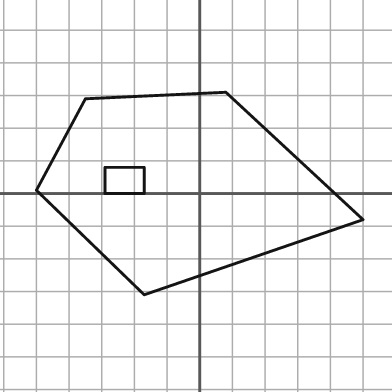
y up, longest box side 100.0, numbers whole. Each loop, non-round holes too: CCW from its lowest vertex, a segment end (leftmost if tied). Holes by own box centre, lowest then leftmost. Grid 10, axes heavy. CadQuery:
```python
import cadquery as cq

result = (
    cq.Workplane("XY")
    .moveTo(-17.0, -31.0)
    .lineTo(50.0, -8.0)
    .lineTo(8.0, 31.0)
    .lineTo(-35.0, 29.0)
    .lineTo(-50.0, 1.0)
    .close()
    .moveTo(-29.0, 0.0)
    .lineTo(-17.0, 0.0)
    .lineTo(-17.0, 8.0)
    .lineTo(-29.0, 8.0)
    .close()
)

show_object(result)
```